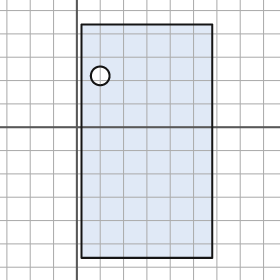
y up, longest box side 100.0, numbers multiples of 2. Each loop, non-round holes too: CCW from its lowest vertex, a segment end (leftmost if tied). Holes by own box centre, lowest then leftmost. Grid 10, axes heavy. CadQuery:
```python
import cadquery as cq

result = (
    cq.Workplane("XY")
    .moveTo(2.0, -56.0)
    .lineTo(58.0, -56.0)
    .lineTo(58.0, 44.0)
    .lineTo(2.0, 44.0)
    .close()
    .moveTo(10.0, 22.0)
    .circle(4.0)
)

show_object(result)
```